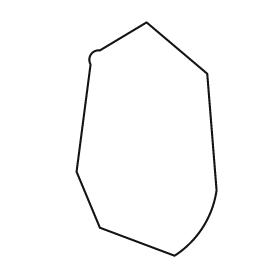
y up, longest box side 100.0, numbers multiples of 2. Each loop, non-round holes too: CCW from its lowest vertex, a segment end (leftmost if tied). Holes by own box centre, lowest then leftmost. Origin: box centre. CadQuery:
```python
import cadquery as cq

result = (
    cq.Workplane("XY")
    .moveTo(12.0, -50.0)
    .threePointArc((24.0, -38.0), (30.0, -22.0))
    .lineTo(26.0, 28.0)
    .lineTo(0.0, 50.0)
    .lineTo(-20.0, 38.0)
    .threePointArc((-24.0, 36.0), (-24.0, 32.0))
    .lineTo(-30.0, -14.0)
    .lineTo(-20.0, -38.0)
    .close()
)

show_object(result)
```